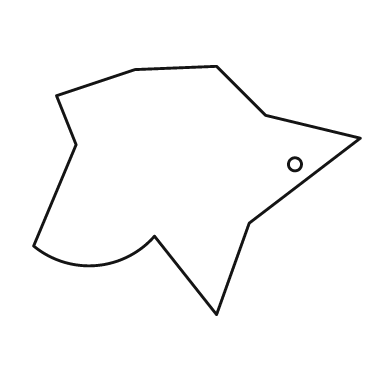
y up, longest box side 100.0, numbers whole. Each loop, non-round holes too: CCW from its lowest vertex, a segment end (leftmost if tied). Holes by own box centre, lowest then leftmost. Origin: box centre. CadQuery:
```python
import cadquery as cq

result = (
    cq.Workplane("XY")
    .moveTo(6.0, -38.0)
    .lineTo(16.0, -10.0)
    .lineTo(50.0, 16.0)
    .lineTo(21.0, 23.0)
    .lineTo(6.0, 38.0)
    .lineTo(-19.0, 37.0)
    .lineTo(-43.0, 29.0)
    .lineTo(-37.0, 14.0)
    .lineTo(-50.0, -17.0)
    .threePointArc((-31.0, -23.0), (-13.0, -14.0))
    .close()
    .moveTo(30.0, 8.0)
    .circle(2.0)
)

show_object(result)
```